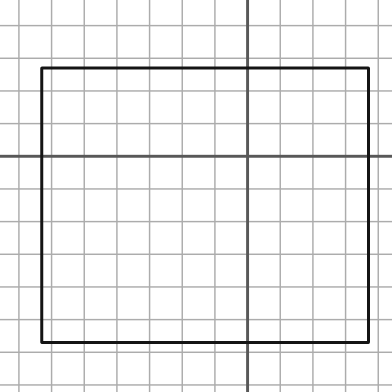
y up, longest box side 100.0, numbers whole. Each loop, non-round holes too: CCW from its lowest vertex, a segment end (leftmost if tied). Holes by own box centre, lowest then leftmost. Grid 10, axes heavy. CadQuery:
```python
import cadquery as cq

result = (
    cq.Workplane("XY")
    .moveTo(-63.0, -57.0)
    .lineTo(37.0, -57.0)
    .lineTo(37.0, 27.0)
    .lineTo(-63.0, 27.0)
    .close()
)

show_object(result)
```